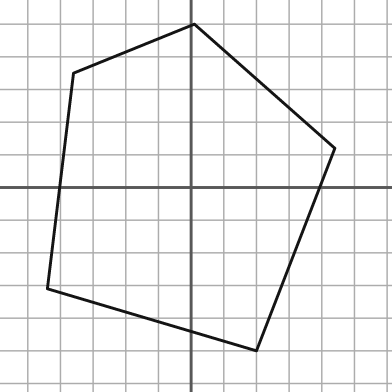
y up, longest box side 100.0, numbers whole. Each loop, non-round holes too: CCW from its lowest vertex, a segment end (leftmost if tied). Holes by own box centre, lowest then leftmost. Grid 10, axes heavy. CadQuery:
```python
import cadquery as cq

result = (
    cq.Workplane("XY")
    .moveTo(20.0, -50.0)
    .lineTo(44.0, 12.0)
    .lineTo(1.0, 50.0)
    .lineTo(-36.0, 35.0)
    .lineTo(-44.0, -31.0)
    .close()
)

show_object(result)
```